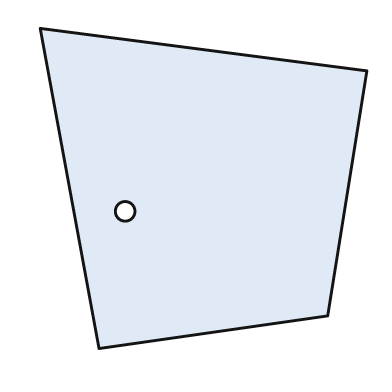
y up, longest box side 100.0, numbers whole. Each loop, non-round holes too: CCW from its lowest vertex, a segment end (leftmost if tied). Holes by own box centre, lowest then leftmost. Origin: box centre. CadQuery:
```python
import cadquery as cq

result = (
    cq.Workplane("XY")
    .moveTo(-32.0, -49.0)
    .lineTo(38.0, -39.0)
    .lineTo(50.0, 36.0)
    .lineTo(-50.0, 49.0)
    .close()
    .moveTo(-24.0, -7.0)
    .circle(3.0)
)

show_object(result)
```